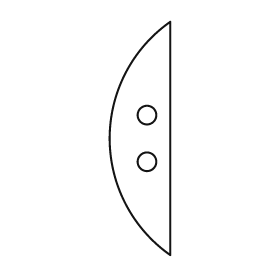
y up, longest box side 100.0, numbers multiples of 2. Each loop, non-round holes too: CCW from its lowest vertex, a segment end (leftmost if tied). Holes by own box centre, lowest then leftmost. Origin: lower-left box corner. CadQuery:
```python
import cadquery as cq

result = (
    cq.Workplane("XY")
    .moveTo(26.0, 0.0)
    .lineTo(26.0, 100.0)
    .threePointArc((0.0, 50.0), (26.0, 0.0))
    .close()
    .moveTo(16.0, 40.0)
    .circle(4.0)
    .moveTo(16.0, 60.0)
    .circle(4.0)
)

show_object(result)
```